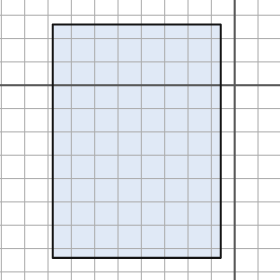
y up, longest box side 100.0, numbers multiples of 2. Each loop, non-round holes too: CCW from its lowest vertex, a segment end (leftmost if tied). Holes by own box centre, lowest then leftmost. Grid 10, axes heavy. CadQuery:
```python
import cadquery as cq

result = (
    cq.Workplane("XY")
    .moveTo(-78.0, -74.0)
    .lineTo(-6.0, -74.0)
    .lineTo(-6.0, 26.0)
    .lineTo(-78.0, 26.0)
    .close()
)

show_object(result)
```